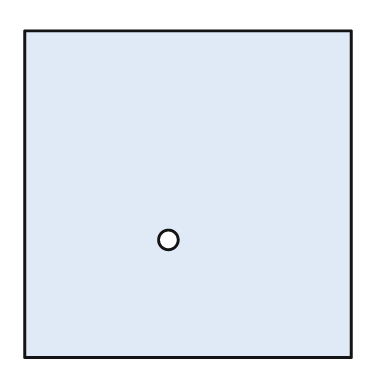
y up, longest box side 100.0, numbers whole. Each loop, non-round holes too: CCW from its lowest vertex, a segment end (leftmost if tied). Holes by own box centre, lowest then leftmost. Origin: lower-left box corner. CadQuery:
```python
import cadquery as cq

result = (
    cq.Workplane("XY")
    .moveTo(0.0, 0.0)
    .lineTo(100.0, 0.0)
    .lineTo(100.0, 100.0)
    .lineTo(0.0, 100.0)
    .close()
    .moveTo(44.0, 36.0)
    .circle(3.0)
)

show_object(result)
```